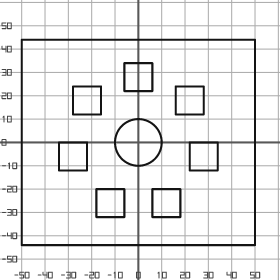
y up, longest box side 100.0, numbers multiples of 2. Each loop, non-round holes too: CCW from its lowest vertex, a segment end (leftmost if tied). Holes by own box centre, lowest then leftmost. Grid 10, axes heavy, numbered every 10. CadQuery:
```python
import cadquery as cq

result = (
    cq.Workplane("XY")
    .moveTo(-50.0, -44.0)
    .lineTo(50.0, -44.0)
    .lineTo(50.0, 44.0)
    .lineTo(-50.0, 44.0)
    .close()
    .moveTo(-18.0, -32.0)
    .lineTo(-6.0, -32.0)
    .lineTo(-6.0, -20.0)
    .lineTo(-18.0, -20.0)
    .close()
    .moveTo(6.0, -32.0)
    .lineTo(18.0, -32.0)
    .lineTo(18.0, -20.0)
    .lineTo(6.0, -20.0)
    .close()
    .moveTo(-34.0, -12.0)
    .lineTo(-22.0, -12.0)
    .lineTo(-22.0, 0.0)
    .lineTo(-34.0, 0.0)
    .close()
    .moveTo(22.0, -12.0)
    .lineTo(34.0, -12.0)
    .lineTo(34.0, 0.0)
    .lineTo(22.0, 0.0)
    .close()
    .moveTo(0.0, 0.0)
    .circle(10.0)
    .moveTo(-28.0, 12.0)
    .lineTo(-16.0, 12.0)
    .lineTo(-16.0, 24.0)
    .lineTo(-28.0, 24.0)
    .close()
    .moveTo(16.0, 12.0)
    .lineTo(28.0, 12.0)
    .lineTo(28.0, 24.0)
    .lineTo(16.0, 24.0)
    .close()
    .moveTo(-6.0, 22.0)
    .lineTo(6.0, 22.0)
    .lineTo(6.0, 34.0)
    .lineTo(-6.0, 34.0)
    .close()
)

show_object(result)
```